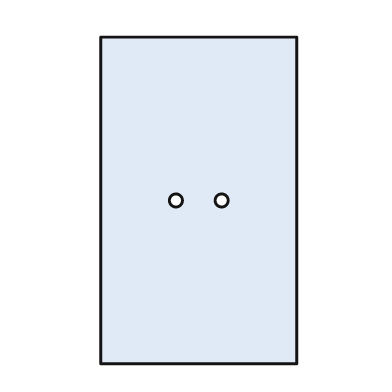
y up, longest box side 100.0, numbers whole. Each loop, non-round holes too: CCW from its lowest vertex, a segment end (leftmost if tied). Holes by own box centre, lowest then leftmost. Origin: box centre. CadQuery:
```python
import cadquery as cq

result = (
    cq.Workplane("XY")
    .moveTo(-30.0, -50.0)
    .lineTo(30.0, -50.0)
    .lineTo(30.0, 50.0)
    .lineTo(-30.0, 50.0)
    .close()
    .moveTo(-7.0, 0.0)
    .circle(2.0)
    .moveTo(7.0, 0.0)
    .circle(2.0)
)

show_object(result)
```